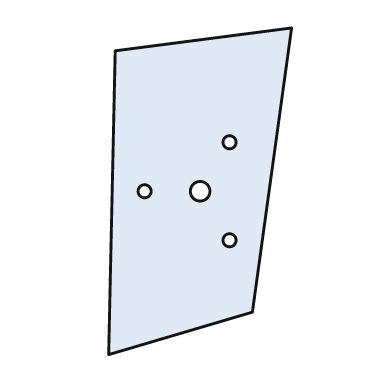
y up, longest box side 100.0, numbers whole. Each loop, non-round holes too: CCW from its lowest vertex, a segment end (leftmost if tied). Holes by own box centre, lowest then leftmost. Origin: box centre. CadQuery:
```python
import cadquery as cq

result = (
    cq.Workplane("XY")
    .moveTo(-28.0, -50.0)
    .lineTo(16.0, -37.0)
    .lineTo(28.0, 50.0)
    .lineTo(-26.0, 43.0)
    .close()
    .moveTo(9.0, -15.0)
    .circle(2.0)
    .moveTo(-17.0, 0.0)
    .circle(2.0)
    .moveTo(0.0, 0.0)
    .circle(3.0)
    .moveTo(9.0, 15.0)
    .circle(2.0)
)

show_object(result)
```